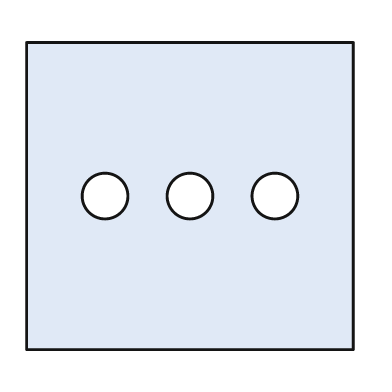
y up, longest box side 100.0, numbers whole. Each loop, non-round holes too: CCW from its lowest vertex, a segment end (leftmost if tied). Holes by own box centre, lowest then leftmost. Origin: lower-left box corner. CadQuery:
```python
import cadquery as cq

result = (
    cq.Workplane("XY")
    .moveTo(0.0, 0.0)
    .lineTo(100.0, 0.0)
    .lineTo(100.0, 94.0)
    .lineTo(0.0, 94.0)
    .close()
    .moveTo(24.0, 47.0)
    .circle(7.0)
    .moveTo(50.0, 47.0)
    .circle(7.0)
    .moveTo(76.0, 47.0)
    .circle(7.0)
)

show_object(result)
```